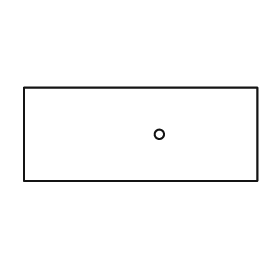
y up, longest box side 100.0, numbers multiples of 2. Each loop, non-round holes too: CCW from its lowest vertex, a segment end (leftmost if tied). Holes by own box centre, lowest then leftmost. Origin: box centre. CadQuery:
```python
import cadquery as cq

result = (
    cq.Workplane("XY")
    .moveTo(-50.0, -20.0)
    .lineTo(50.0, -20.0)
    .lineTo(50.0, 20.0)
    .lineTo(-50.0, 20.0)
    .close()
    .moveTo(8.0, 0.0)
    .circle(2.0)
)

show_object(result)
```